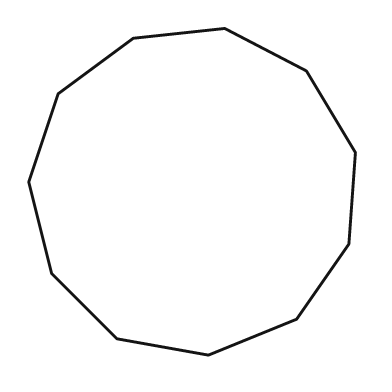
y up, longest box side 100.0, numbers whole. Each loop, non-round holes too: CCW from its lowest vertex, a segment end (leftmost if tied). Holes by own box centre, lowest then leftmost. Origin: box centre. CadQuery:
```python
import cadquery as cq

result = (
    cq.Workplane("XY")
    .moveTo(5.0, -50.0)
    .lineTo(32.0, -39.0)
    .lineTo(48.0, -16.0)
    .lineTo(50.0, 12.0)
    .lineTo(35.0, 37.0)
    .lineTo(10.0, 50.0)
    .lineTo(-18.0, 47.0)
    .lineTo(-41.0, 30.0)
    .lineTo(-50.0, 3.0)
    .lineTo(-43.0, -25.0)
    .lineTo(-23.0, -45.0)
    .close()
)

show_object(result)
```